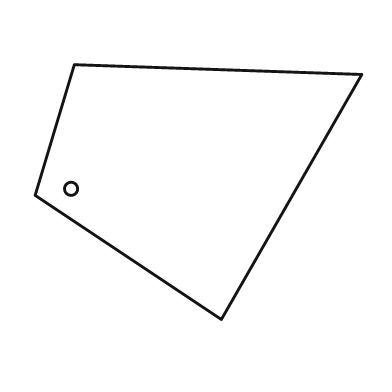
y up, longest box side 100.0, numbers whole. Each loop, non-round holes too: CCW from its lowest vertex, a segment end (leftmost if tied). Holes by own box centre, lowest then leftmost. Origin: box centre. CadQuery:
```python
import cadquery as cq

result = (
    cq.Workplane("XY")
    .moveTo(7.0, -39.0)
    .lineTo(50.0, 36.0)
    .lineTo(-38.0, 39.0)
    .lineTo(-50.0, -1.0)
    .close()
    .moveTo(-39.0, 1.0)
    .circle(2.0)
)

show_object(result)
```